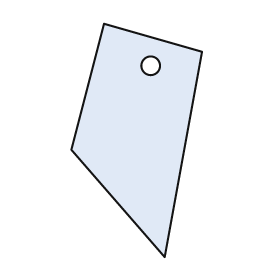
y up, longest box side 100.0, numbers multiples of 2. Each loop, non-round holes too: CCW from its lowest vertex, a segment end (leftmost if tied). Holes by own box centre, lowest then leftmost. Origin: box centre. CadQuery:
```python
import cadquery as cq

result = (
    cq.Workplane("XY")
    .moveTo(12.0, -50.0)
    .lineTo(28.0, 38.0)
    .lineTo(-14.0, 50.0)
    .lineTo(-28.0, -4.0)
    .close()
    .moveTo(6.0, 32.0)
    .circle(4.0)
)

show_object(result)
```